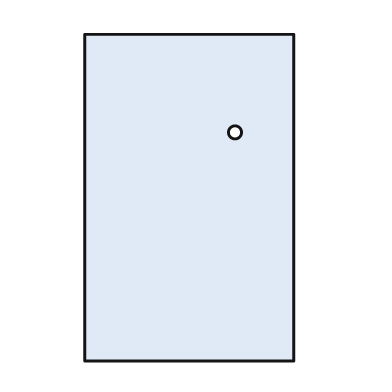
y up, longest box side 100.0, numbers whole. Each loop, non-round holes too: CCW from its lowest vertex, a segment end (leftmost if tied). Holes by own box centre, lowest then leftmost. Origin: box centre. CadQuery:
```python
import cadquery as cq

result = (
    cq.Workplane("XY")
    .moveTo(-32.0, -50.0)
    .lineTo(32.0, -50.0)
    .lineTo(32.0, 50.0)
    .lineTo(-32.0, 50.0)
    .close()
    .moveTo(14.0, 20.0)
    .circle(2.0)
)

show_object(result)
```